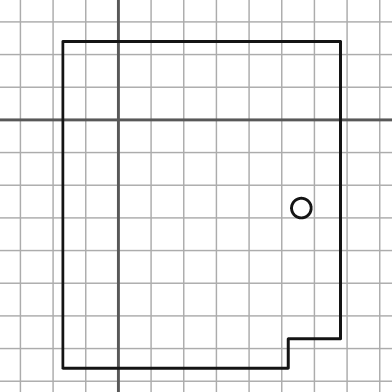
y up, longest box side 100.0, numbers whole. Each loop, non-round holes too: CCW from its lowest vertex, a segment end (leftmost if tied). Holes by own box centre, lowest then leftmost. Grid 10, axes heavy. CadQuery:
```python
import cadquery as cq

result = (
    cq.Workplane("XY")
    .moveTo(-17.0, -76.0)
    .lineTo(52.0, -76.0)
    .lineTo(52.0, -67.0)
    .lineTo(68.0, -67.0)
    .lineTo(68.0, 24.0)
    .lineTo(-17.0, 24.0)
    .close()
    .moveTo(56.0, -27.0)
    .circle(3.0)
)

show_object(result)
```